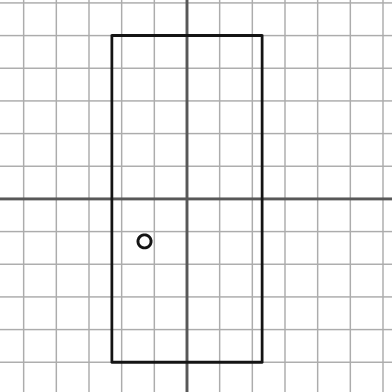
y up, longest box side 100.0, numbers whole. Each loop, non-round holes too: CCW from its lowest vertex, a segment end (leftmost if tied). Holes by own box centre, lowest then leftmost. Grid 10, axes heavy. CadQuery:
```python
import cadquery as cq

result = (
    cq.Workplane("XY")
    .moveTo(-23.0, -50.0)
    .lineTo(23.0, -50.0)
    .lineTo(23.0, 50.0)
    .lineTo(-23.0, 50.0)
    .close()
    .moveTo(-13.0, -13.0)
    .circle(2.0)
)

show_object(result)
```